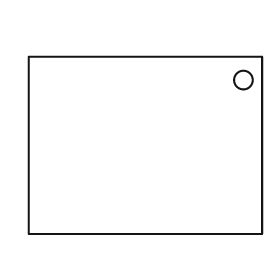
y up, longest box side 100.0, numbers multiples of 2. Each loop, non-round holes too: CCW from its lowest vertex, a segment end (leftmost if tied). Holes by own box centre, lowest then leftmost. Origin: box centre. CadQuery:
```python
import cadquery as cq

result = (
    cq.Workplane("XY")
    .moveTo(-50.0, -38.0)
    .lineTo(50.0, -38.0)
    .lineTo(50.0, 38.0)
    .lineTo(-50.0, 38.0)
    .close()
    .moveTo(42.0, 28.0)
    .circle(4.0)
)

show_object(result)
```